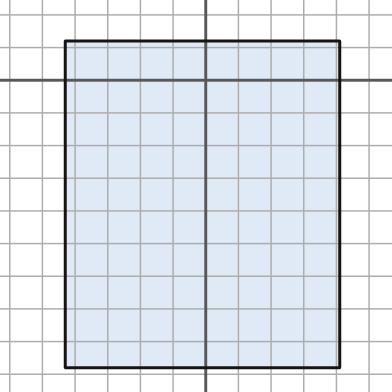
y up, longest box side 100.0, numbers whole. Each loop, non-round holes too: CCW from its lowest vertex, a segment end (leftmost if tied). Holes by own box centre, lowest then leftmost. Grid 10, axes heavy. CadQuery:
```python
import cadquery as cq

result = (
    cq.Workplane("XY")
    .moveTo(-43.0, -88.0)
    .lineTo(41.0, -88.0)
    .lineTo(41.0, 12.0)
    .lineTo(-43.0, 12.0)
    .close()
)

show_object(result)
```